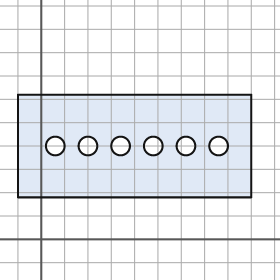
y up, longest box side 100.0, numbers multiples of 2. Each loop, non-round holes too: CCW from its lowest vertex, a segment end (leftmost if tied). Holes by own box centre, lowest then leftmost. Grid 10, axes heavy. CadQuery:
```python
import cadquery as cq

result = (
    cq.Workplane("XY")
    .moveTo(-10.0, 18.0)
    .lineTo(90.0, 18.0)
    .lineTo(90.0, 62.0)
    .lineTo(-10.0, 62.0)
    .close()
    .moveTo(6.0, 40.0)
    .circle(4.0)
    .moveTo(20.0, 40.0)
    .circle(4.0)
    .moveTo(34.0, 40.0)
    .circle(4.0)
    .moveTo(48.0, 40.0)
    .circle(4.0)
    .moveTo(62.0, 40.0)
    .circle(4.0)
    .moveTo(76.0, 40.0)
    .circle(4.0)
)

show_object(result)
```